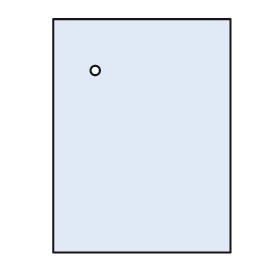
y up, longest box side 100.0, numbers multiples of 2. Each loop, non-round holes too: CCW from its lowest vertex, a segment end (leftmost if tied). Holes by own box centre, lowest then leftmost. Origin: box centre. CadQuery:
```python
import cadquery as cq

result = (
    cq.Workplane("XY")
    .moveTo(-38.0, -50.0)
    .lineTo(38.0, -50.0)
    .lineTo(38.0, 50.0)
    .lineTo(-38.0, 50.0)
    .close()
    .moveTo(-20.0, 28.0)
    .circle(2.0)
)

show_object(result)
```